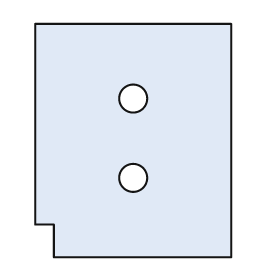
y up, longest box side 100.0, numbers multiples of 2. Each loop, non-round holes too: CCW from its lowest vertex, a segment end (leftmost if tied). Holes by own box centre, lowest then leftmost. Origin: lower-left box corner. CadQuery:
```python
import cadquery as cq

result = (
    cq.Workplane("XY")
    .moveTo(8.0, 0.0)
    .lineTo(84.0, 0.0)
    .lineTo(84.0, 100.0)
    .lineTo(0.0, 100.0)
    .lineTo(0.0, 14.0)
    .lineTo(8.0, 14.0)
    .close()
    .moveTo(42.0, 34.0)
    .circle(6.0)
    .moveTo(42.0, 68.0)
    .circle(6.0)
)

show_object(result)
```